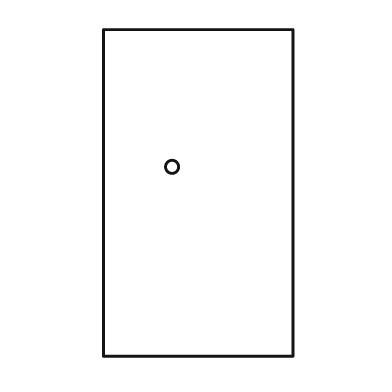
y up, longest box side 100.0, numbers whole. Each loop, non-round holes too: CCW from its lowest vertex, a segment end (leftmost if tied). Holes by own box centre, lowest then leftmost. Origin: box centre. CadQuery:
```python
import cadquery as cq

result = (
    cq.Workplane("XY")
    .moveTo(-29.0, -50.0)
    .lineTo(29.0, -50.0)
    .lineTo(29.0, 50.0)
    .lineTo(-29.0, 50.0)
    .close()
    .moveTo(-8.0, 8.0)
    .circle(2.0)
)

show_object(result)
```